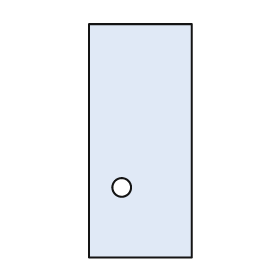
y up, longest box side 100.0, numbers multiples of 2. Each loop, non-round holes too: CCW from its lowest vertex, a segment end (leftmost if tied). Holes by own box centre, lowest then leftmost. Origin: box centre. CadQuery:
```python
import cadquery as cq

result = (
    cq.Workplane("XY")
    .moveTo(-22.0, -50.0)
    .lineTo(22.0, -50.0)
    .lineTo(22.0, 50.0)
    .lineTo(-22.0, 50.0)
    .close()
    .moveTo(-8.0, -20.0)
    .circle(4.0)
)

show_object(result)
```